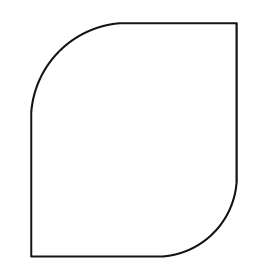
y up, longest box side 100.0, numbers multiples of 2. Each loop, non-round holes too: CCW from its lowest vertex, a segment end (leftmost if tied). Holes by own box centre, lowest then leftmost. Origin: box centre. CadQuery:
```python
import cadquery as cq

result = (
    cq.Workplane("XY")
    .moveTo(-44.0, -50.0)
    .lineTo(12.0, -50.0)
    .threePointArc((34.0, -40.0), (44.0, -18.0))
    .lineTo(44.0, 50.0)
    .lineTo(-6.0, 50.0)
    .threePointArc((-32.0, 38.0), (-44.0, 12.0))
    .close()
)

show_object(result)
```